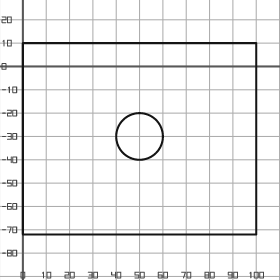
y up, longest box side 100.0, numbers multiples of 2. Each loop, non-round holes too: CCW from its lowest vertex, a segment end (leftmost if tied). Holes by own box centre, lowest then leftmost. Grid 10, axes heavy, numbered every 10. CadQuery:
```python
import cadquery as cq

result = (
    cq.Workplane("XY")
    .moveTo(0.0, -72.0)
    .lineTo(100.0, -72.0)
    .lineTo(100.0, 10.0)
    .lineTo(0.0, 10.0)
    .close()
    .moveTo(50.0, -30.0)
    .circle(10.0)
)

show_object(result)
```